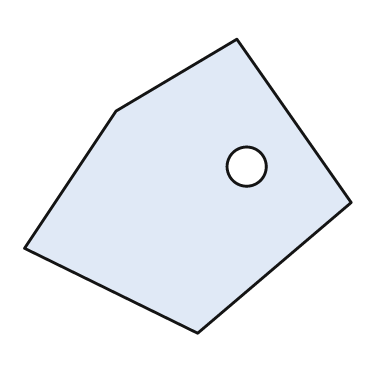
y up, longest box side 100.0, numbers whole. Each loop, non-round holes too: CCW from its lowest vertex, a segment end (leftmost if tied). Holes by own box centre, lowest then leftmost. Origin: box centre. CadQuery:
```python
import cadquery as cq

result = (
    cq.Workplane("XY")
    .moveTo(3.0, -45.0)
    .lineTo(50.0, -5.0)
    .lineTo(15.0, 45.0)
    .lineTo(-22.0, 23.0)
    .lineTo(-50.0, -19.0)
    .close()
    .moveTo(18.0, 6.0)
    .circle(6.0)
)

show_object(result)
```